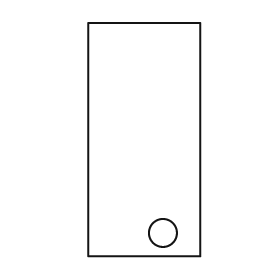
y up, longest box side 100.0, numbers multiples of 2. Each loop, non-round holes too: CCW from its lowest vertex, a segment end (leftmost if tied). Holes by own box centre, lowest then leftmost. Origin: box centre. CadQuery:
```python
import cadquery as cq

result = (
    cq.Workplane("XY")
    .moveTo(-24.0, -50.0)
    .lineTo(24.0, -50.0)
    .lineTo(24.0, 50.0)
    .lineTo(-24.0, 50.0)
    .close()
    .moveTo(8.0, -40.0)
    .circle(6.0)
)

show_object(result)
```